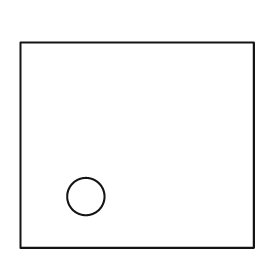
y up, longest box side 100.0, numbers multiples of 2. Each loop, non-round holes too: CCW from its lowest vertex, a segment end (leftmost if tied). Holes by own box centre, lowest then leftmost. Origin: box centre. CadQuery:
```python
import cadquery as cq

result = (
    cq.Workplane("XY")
    .moveTo(-50.0, -44.0)
    .lineTo(50.0, -44.0)
    .lineTo(50.0, 44.0)
    .lineTo(-50.0, 44.0)
    .close()
    .moveTo(-22.0, -22.0)
    .circle(8.0)
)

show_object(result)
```